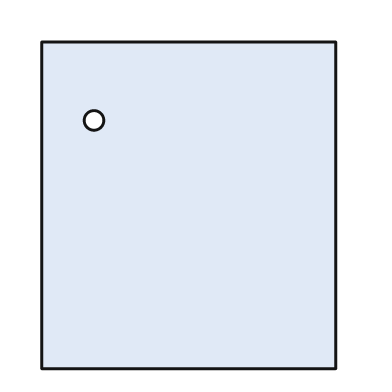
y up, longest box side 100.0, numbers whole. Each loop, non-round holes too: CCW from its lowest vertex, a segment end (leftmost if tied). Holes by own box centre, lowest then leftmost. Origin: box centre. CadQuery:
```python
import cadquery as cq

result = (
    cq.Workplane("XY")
    .moveTo(-45.0, -50.0)
    .lineTo(45.0, -50.0)
    .lineTo(45.0, 50.0)
    .lineTo(-45.0, 50.0)
    .close()
    .moveTo(-29.0, 26.0)
    .circle(3.0)
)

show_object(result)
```